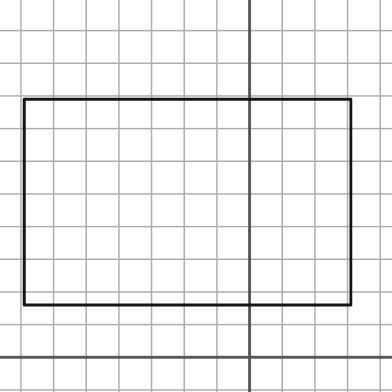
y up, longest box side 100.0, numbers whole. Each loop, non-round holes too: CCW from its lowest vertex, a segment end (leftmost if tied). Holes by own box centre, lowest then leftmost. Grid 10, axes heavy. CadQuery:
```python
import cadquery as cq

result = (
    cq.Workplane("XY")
    .moveTo(-69.0, 16.0)
    .lineTo(31.0, 16.0)
    .lineTo(31.0, 79.0)
    .lineTo(-69.0, 79.0)
    .close()
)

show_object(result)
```